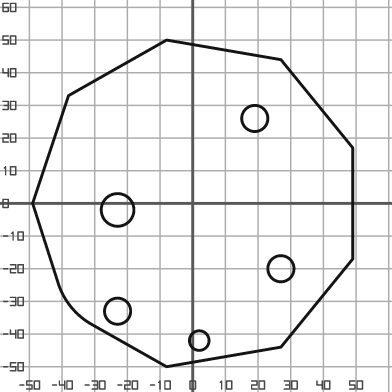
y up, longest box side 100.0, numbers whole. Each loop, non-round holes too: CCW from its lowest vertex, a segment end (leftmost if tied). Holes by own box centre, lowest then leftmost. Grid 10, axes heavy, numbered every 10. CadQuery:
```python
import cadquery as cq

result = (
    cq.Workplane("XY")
    .moveTo(-8.0, -50.0)
    .lineTo(27.0, -44.0)
    .lineTo(49.0, -17.0)
    .lineTo(49.0, 17.0)
    .lineTo(27.0, 44.0)
    .lineTo(-8.0, 50.0)
    .lineTo(-38.0, 33.0)
    .lineTo(-49.0, 0.0)
    .lineTo(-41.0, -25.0)
    .threePointArc((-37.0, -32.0), (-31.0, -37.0))
    .close()
    .moveTo(2.0, -42.0)
    .circle(3.0)
    .moveTo(-23.0, -33.0)
    .circle(4.0)
    .moveTo(27.0, -20.0)
    .circle(4.0)
    .moveTo(-23.0, -2.0)
    .circle(5.0)
    .moveTo(19.0, 26.0)
    .circle(4.0)
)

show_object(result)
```